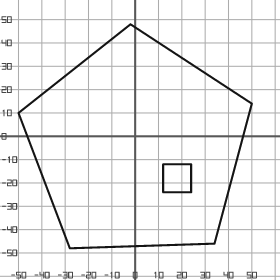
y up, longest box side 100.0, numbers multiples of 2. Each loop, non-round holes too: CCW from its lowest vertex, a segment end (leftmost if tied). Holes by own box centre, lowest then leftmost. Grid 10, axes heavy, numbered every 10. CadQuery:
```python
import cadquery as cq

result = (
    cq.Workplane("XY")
    .moveTo(-28.0, -48.0)
    .lineTo(34.0, -46.0)
    .lineTo(50.0, 14.0)
    .lineTo(-2.0, 48.0)
    .lineTo(-50.0, 10.0)
    .close()
    .moveTo(12.0, -24.0)
    .lineTo(24.0, -24.0)
    .lineTo(24.0, -12.0)
    .lineTo(12.0, -12.0)
    .close()
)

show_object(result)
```